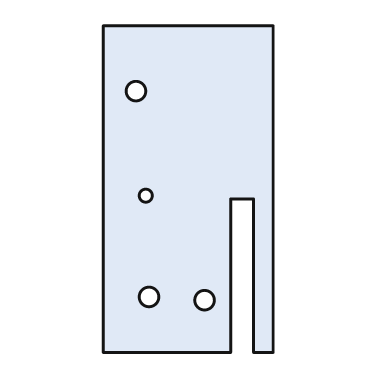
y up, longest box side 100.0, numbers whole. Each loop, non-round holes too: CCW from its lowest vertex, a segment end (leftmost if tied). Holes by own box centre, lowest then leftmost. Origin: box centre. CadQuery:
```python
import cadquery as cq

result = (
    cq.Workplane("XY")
    .moveTo(-26.0, -50.0)
    .lineTo(13.0, -50.0)
    .lineTo(13.0, -3.0)
    .lineTo(20.0, -3.0)
    .lineTo(20.0, -50.0)
    .lineTo(26.0, -50.0)
    .lineTo(26.0, 50.0)
    .lineTo(-26.0, 50.0)
    .close()
    .moveTo(5.0, -34.0)
    .circle(3.0)
    .moveTo(-12.0, -33.0)
    .circle(3.0)
    .moveTo(-13.0, -2.0)
    .circle(2.0)
    .moveTo(-16.0, 30.0)
    .circle(3.0)
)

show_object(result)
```